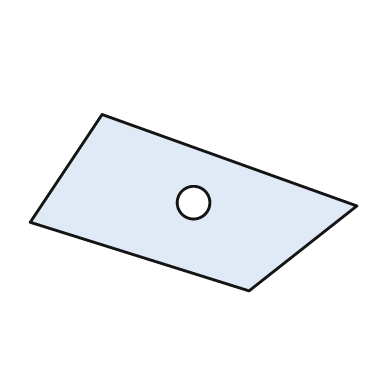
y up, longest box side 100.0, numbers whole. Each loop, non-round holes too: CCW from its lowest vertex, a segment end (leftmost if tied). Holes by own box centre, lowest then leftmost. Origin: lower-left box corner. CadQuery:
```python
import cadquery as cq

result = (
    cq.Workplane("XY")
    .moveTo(67.0, 0.0)
    .lineTo(100.0, 26.0)
    .lineTo(22.0, 54.0)
    .lineTo(0.0, 21.0)
    .close()
    .moveTo(50.0, 27.0)
    .circle(5.0)
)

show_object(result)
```